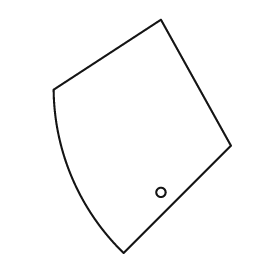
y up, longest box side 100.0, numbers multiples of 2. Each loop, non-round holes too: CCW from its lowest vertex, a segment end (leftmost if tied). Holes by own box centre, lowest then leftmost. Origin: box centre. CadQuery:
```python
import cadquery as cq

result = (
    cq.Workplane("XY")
    .moveTo(-8.0, -50.0)
    .lineTo(38.0, -4.0)
    .lineTo(8.0, 50.0)
    .lineTo(-38.0, 20.0)
    .threePointArc((-30.0, -18.0), (-8.0, -50.0))
    .close()
    .moveTo(8.0, -24.0)
    .circle(2.0)
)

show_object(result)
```